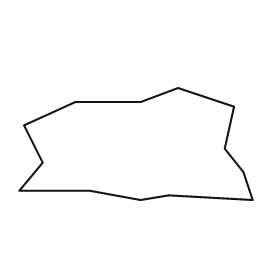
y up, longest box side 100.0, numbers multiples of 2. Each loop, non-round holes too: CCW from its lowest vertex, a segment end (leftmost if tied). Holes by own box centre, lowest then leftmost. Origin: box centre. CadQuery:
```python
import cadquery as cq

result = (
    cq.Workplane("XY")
    .moveTo(2.0, -24.0)
    .lineTo(14.0, -22.0)
    .lineTo(50.0, -24.0)
    .lineTo(46.0, -12.0)
    .lineTo(38.0, -2.0)
    .lineTo(42.0, 16.0)
    .lineTo(18.0, 24.0)
    .lineTo(2.0, 18.0)
    .lineTo(-26.0, 18.0)
    .lineTo(-48.0, 8.0)
    .lineTo(-40.0, -8.0)
    .lineTo(-50.0, -20.0)
    .lineTo(-20.0, -20.0)
    .close()
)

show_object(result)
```